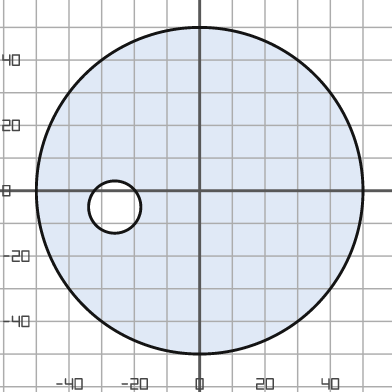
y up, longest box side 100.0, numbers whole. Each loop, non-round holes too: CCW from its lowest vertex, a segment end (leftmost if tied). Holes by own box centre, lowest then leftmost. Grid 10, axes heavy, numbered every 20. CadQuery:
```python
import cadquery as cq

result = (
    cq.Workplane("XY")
    .moveTo(0.0, 0.0)
    .circle(50.0)
    .moveTo(-26.0, -5.0)
    .circle(8.0)
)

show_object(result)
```